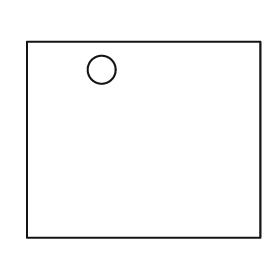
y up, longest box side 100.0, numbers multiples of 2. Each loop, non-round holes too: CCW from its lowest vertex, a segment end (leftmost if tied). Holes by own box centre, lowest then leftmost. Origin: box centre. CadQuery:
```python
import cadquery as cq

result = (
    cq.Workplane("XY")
    .moveTo(-50.0, -42.0)
    .lineTo(50.0, -42.0)
    .lineTo(50.0, 42.0)
    .lineTo(-50.0, 42.0)
    .close()
    .moveTo(-18.0, 30.0)
    .circle(6.0)
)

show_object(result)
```